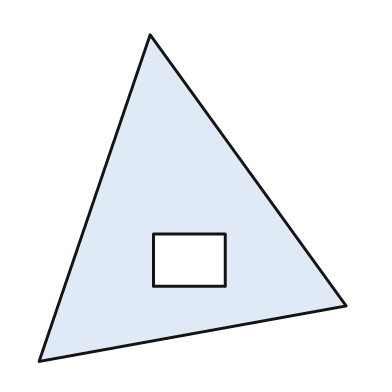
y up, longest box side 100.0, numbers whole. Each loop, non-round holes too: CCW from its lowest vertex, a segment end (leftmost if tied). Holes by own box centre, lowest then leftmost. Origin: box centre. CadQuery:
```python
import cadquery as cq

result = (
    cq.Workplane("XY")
    .moveTo(-47.0, -50.0)
    .lineTo(47.0, -33.0)
    .lineTo(-13.0, 50.0)
    .close()
    .moveTo(-12.0, -27.0)
    .lineTo(10.0, -27.0)
    .lineTo(10.0, -11.0)
    .lineTo(-12.0, -11.0)
    .close()
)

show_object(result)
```